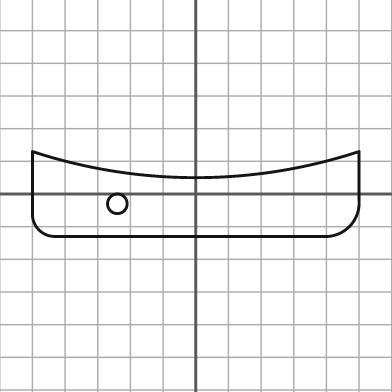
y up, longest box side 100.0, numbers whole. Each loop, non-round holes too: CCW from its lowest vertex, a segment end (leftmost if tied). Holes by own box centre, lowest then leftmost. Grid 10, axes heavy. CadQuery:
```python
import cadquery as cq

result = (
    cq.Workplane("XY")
    .moveTo(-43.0, -13.0)
    .lineTo(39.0, -13.0)
    .threePointArc((47.0, -10.0), (50.0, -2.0))
    .lineTo(50.0, 13.0)
    .threePointArc((0.0, 5.0), (-50.0, 13.0))
    .lineTo(-50.0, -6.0)
    .threePointArc((-48.0, -11.0), (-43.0, -13.0))
    .close()
    .moveTo(-24.0, -3.0)
    .circle(3.0)
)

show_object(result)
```